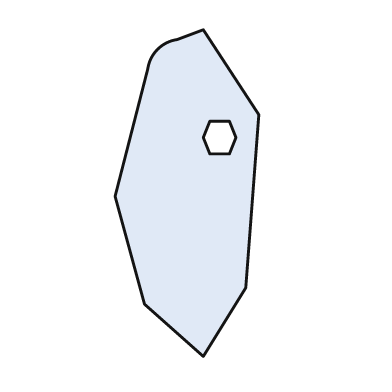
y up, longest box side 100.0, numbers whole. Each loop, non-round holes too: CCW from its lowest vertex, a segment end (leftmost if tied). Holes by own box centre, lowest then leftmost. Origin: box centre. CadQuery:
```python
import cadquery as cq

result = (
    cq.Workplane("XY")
    .moveTo(5.0, -50.0)
    .lineTo(18.0, -29.0)
    .lineTo(22.0, 24.0)
    .lineTo(5.0, 50.0)
    .lineTo(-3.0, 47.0)
    .threePointArc((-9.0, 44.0), (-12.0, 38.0))
    .lineTo(-22.0, -1.0)
    .lineTo(-13.0, -34.0)
    .close()
    .moveTo(7.0, 12.0)
    .lineTo(13.0, 12.0)
    .lineTo(15.0, 17.0)
    .lineTo(13.0, 22.0)
    .lineTo(7.0, 22.0)
    .lineTo(5.0, 17.0)
    .close()
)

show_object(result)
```